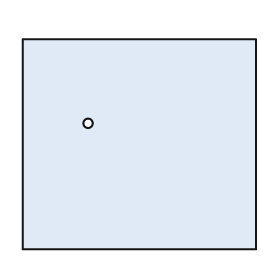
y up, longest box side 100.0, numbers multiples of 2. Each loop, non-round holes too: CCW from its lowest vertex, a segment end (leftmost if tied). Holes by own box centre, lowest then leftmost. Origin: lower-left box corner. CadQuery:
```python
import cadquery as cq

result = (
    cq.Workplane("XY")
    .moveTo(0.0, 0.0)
    .lineTo(100.0, 0.0)
    .lineTo(100.0, 90.0)
    .lineTo(0.0, 90.0)
    .close()
    .moveTo(28.0, 54.0)
    .circle(2.0)
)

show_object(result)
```